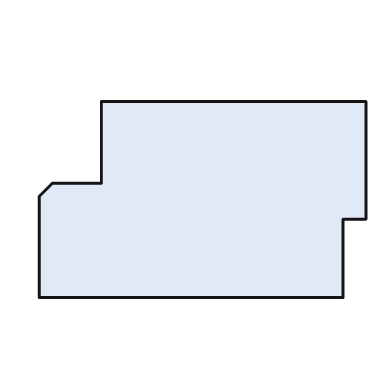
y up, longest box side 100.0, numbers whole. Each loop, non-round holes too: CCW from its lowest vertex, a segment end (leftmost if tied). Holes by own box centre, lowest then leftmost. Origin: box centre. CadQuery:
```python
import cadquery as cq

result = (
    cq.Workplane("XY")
    .moveTo(-50.0, -30.0)
    .lineTo(43.0, -30.0)
    .lineTo(43.0, -6.0)
    .lineTo(50.0, -6.0)
    .lineTo(50.0, 30.0)
    .lineTo(-31.0, 30.0)
    .lineTo(-31.0, 5.0)
    .lineTo(-46.0, 5.0)
    .lineTo(-50.0, 1.0)
    .close()
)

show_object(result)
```